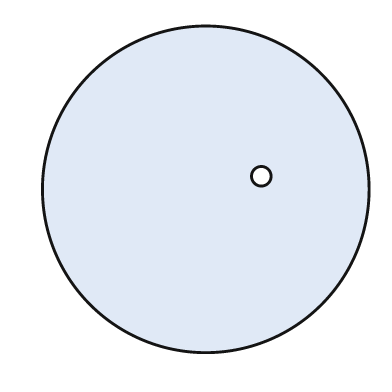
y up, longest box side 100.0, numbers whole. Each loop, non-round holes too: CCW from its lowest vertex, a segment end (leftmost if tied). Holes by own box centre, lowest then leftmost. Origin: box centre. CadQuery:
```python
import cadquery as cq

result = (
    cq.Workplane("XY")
    .moveTo(0.0, 0.0)
    .circle(50.0)
    .moveTo(17.0, 4.0)
    .circle(3.0)
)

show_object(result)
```